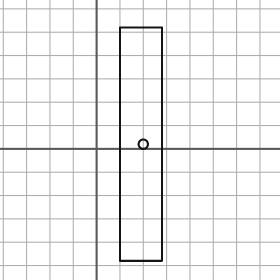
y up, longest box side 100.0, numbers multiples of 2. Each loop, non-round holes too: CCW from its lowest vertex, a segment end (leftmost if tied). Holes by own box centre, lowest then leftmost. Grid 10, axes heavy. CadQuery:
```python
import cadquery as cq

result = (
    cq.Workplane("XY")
    .moveTo(10.0, -48.0)
    .lineTo(28.0, -48.0)
    .lineTo(28.0, 52.0)
    .lineTo(10.0, 52.0)
    .close()
    .moveTo(20.0, 2.0)
    .circle(2.0)
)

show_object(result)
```